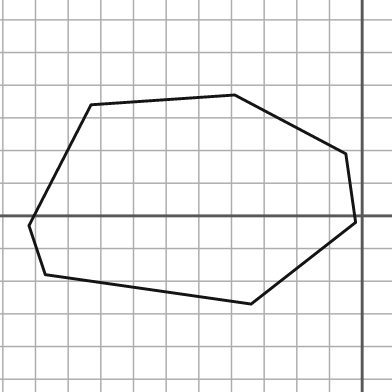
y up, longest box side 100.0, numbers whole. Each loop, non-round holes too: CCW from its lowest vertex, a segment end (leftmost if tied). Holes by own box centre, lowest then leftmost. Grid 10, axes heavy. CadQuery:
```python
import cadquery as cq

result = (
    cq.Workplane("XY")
    .moveTo(-34.0, -27.0)
    .lineTo(-2.0, -2.0)
    .lineTo(-5.0, 19.0)
    .lineTo(-39.0, 37.0)
    .lineTo(-83.0, 34.0)
    .lineTo(-102.0, -3.0)
    .lineTo(-97.0, -18.0)
    .close()
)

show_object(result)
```